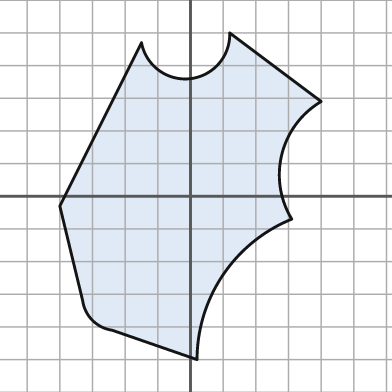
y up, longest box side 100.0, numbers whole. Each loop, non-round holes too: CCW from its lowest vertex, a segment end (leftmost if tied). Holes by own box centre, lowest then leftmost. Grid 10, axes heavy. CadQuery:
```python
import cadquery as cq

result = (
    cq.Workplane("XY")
    .moveTo(2.0, -50.0)
    .threePointArc((10.0, -24.0), (31.0, -7.0))
    .threePointArc((28.0, 13.0), (40.0, 29.0))
    .lineTo(12.0, 50.0)
    .threePointArc((0.0, 36.0), (-15.0, 47.0))
    .lineTo(-40.0, -3.0)
    .lineTo(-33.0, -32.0)
    .threePointArc((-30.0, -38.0), (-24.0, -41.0))
    .close()
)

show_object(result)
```